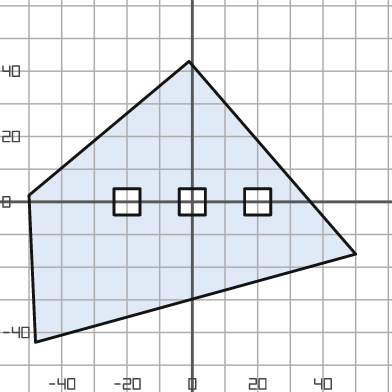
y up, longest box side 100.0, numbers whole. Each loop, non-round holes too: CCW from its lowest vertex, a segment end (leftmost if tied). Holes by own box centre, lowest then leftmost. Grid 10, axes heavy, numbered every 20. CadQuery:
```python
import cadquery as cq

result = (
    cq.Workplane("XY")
    .moveTo(-48.0, -43.0)
    .lineTo(50.0, -16.0)
    .lineTo(-1.0, 43.0)
    .lineTo(-50.0, 2.0)
    .close()
    .moveTo(-24.0, -4.0)
    .lineTo(-16.0, -4.0)
    .lineTo(-16.0, 4.0)
    .lineTo(-24.0, 4.0)
    .close()
    .moveTo(-4.0, -4.0)
    .lineTo(4.0, -4.0)
    .lineTo(4.0, 4.0)
    .lineTo(-4.0, 4.0)
    .close()
    .moveTo(16.0, -4.0)
    .lineTo(24.0, -4.0)
    .lineTo(24.0, 4.0)
    .lineTo(16.0, 4.0)
    .close()
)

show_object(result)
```